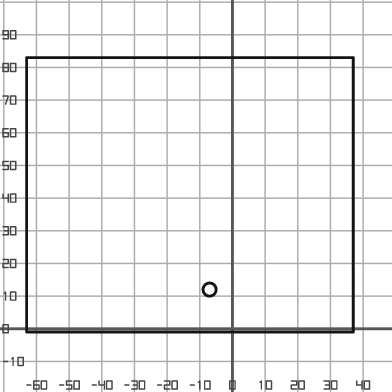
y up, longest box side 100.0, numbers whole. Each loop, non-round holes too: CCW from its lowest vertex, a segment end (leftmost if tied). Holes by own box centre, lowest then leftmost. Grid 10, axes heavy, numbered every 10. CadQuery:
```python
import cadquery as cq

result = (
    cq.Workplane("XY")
    .moveTo(-63.0, -1.0)
    .lineTo(37.0, -1.0)
    .lineTo(37.0, 83.0)
    .lineTo(-63.0, 83.0)
    .close()
    .moveTo(-7.0, 12.0)
    .circle(2.0)
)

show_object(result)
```